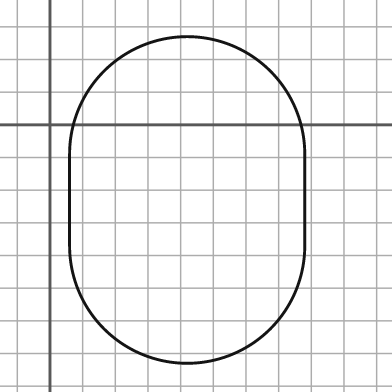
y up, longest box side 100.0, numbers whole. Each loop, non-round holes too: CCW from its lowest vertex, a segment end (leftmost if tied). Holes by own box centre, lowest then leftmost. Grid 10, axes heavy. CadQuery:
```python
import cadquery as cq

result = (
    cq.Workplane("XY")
    .moveTo(6.0, -37.0)
    .threePointArc((42.0, -73.0), (78.0, -37.0))
    .lineTo(78.0, -9.0)
    .threePointArc((42.0, 27.0), (6.0, -9.0))
    .close()
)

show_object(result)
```